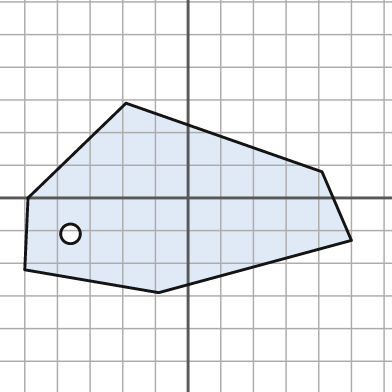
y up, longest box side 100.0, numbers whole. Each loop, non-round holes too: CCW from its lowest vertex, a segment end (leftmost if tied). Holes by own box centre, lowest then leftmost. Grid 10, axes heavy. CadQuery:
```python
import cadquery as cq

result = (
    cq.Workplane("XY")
    .moveTo(-9.0, -29.0)
    .lineTo(50.0, -13.0)
    .lineTo(41.0, 8.0)
    .lineTo(-19.0, 29.0)
    .lineTo(-49.0, 0.0)
    .lineTo(-50.0, -22.0)
    .close()
    .moveTo(-36.0, -11.0)
    .circle(3.0)
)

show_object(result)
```